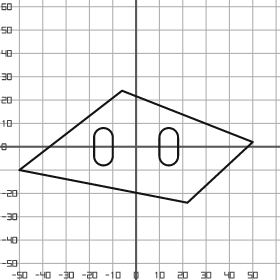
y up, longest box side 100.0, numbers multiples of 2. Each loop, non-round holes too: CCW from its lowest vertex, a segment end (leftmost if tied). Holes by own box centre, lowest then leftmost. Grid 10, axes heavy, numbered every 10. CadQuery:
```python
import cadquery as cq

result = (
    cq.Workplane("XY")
    .moveTo(22.0, -24.0)
    .lineTo(50.0, 2.0)
    .lineTo(-6.0, 24.0)
    .lineTo(-50.0, -10.0)
    .close()
    .moveTo(-18.0, -4.0)
    .threePointArc((-14.0, -8.0), (-10.0, -4.0))
    .lineTo(-10.0, 4.0)
    .threePointArc((-14.0, 8.0), (-18.0, 4.0))
    .close()
    .moveTo(10.0, -4.0)
    .threePointArc((14.0, -8.0), (18.0, -4.0))
    .lineTo(18.0, 4.0)
    .threePointArc((14.0, 8.0), (10.0, 4.0))
    .close()
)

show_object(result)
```